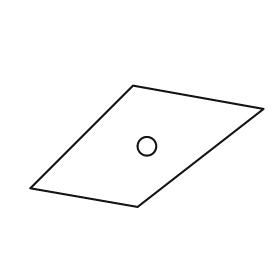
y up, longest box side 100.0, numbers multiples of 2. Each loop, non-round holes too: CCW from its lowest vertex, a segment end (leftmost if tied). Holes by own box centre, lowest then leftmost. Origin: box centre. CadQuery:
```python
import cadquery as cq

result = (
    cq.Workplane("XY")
    .moveTo(-4.0, -26.0)
    .lineTo(50.0, 16.0)
    .lineTo(-6.0, 26.0)
    .lineTo(-50.0, -18.0)
    .close()
    .moveTo(0.0, 0.0)
    .circle(4.0)
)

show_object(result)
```